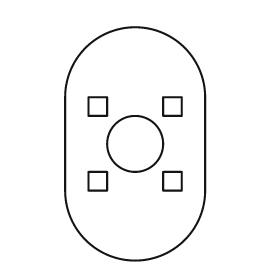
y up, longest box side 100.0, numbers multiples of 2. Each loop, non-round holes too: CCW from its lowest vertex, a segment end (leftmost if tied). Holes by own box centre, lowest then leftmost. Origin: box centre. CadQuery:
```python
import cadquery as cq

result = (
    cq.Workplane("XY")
    .moveTo(-30.0, -20.0)
    .threePointArc((0.0, -50.0), (30.0, -20.0))
    .lineTo(30.0, 20.0)
    .threePointArc((0.0, 50.0), (-30.0, 20.0))
    .close()
    .moveTo(-20.0, -20.0)
    .lineTo(-12.0, -20.0)
    .lineTo(-12.0, -12.0)
    .lineTo(-20.0, -12.0)
    .close()
    .moveTo(12.0, -20.0)
    .lineTo(20.0, -20.0)
    .lineTo(20.0, -12.0)
    .lineTo(12.0, -12.0)
    .close()
    .moveTo(0.0, 0.0)
    .circle(12.0)
    .moveTo(-20.0, 12.0)
    .lineTo(-12.0, 12.0)
    .lineTo(-12.0, 20.0)
    .lineTo(-20.0, 20.0)
    .close()
    .moveTo(12.0, 12.0)
    .lineTo(20.0, 12.0)
    .lineTo(20.0, 20.0)
    .lineTo(12.0, 20.0)
    .close()
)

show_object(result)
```